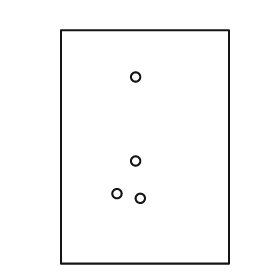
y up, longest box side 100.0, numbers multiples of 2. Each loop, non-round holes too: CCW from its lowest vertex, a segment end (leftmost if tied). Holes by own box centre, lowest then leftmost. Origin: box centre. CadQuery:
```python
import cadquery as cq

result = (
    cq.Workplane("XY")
    .moveTo(-36.0, -50.0)
    .lineTo(36.0, -50.0)
    .lineTo(36.0, 50.0)
    .lineTo(-36.0, 50.0)
    .close()
    .moveTo(-2.0, -22.0)
    .circle(2.0)
    .moveTo(-12.0, -20.0)
    .circle(2.0)
    .moveTo(-4.0, -6.0)
    .circle(2.0)
    .moveTo(-4.0, 30.0)
    .circle(2.0)
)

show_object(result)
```